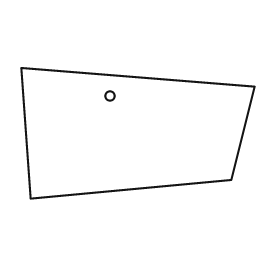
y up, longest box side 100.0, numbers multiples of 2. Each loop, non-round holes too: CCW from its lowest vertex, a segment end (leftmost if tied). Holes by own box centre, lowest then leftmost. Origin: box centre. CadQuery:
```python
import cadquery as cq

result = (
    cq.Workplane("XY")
    .moveTo(-46.0, -28.0)
    .lineTo(40.0, -20.0)
    .lineTo(50.0, 20.0)
    .lineTo(-50.0, 28.0)
    .close()
    .moveTo(-12.0, 16.0)
    .circle(2.0)
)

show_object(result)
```